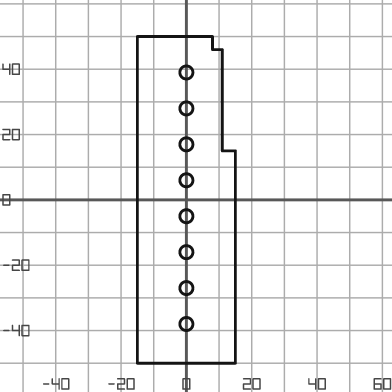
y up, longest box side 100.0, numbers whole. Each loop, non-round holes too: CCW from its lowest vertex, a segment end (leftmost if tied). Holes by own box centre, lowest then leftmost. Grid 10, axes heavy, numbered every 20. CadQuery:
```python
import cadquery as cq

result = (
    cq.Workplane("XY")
    .moveTo(-15.0, -50.0)
    .lineTo(15.0, -50.0)
    .lineTo(15.0, 15.0)
    .lineTo(11.0, 15.0)
    .lineTo(11.0, 46.0)
    .lineTo(8.0, 46.0)
    .lineTo(8.0, 50.0)
    .lineTo(-15.0, 50.0)
    .close()
    .moveTo(0.0, -38.0)
    .circle(2.0)
    .moveTo(0.0, -27.0)
    .circle(2.0)
    .moveTo(0.0, -16.0)
    .circle(2.0)
    .moveTo(0.0, -5.0)
    .circle(2.0)
    .moveTo(0.0, 6.0)
    .circle(2.0)
    .moveTo(0.0, 17.0)
    .circle(2.0)
    .moveTo(0.0, 28.0)
    .circle(2.0)
    .moveTo(0.0, 39.0)
    .circle(2.0)
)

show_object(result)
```